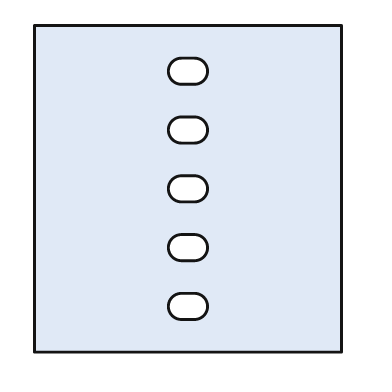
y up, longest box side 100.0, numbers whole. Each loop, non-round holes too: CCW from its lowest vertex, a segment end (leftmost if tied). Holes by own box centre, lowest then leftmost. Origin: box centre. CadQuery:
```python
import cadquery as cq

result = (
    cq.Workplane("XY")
    .moveTo(-47.0, -50.0)
    .lineTo(47.0, -50.0)
    .lineTo(47.0, 50.0)
    .lineTo(-47.0, 50.0)
    .close()
    .moveTo(-2.0, -40.0)
    .lineTo(2.0, -40.0)
    .threePointArc((6.0, -36.0), (2.0, -32.0))
    .lineTo(-2.0, -32.0)
    .threePointArc((-6.0, -36.0), (-2.0, -40.0))
    .close()
    .moveTo(-2.0, -22.0)
    .lineTo(2.0, -22.0)
    .threePointArc((6.0, -18.0), (2.0, -14.0))
    .lineTo(-2.0, -14.0)
    .threePointArc((-6.0, -18.0), (-2.0, -22.0))
    .close()
    .moveTo(-2.0, -4.0)
    .lineTo(2.0, -4.0)
    .threePointArc((6.0, 0.0), (2.0, 4.0))
    .lineTo(-2.0, 4.0)
    .threePointArc((-6.0, 0.0), (-2.0, -4.0))
    .close()
    .moveTo(-2.0, 14.0)
    .lineTo(2.0, 14.0)
    .threePointArc((6.0, 18.0), (2.0, 22.0))
    .lineTo(-2.0, 22.0)
    .threePointArc((-6.0, 18.0), (-2.0, 14.0))
    .close()
    .moveTo(-2.0, 32.0)
    .lineTo(2.0, 32.0)
    .threePointArc((6.0, 36.0), (2.0, 40.0))
    .lineTo(-2.0, 40.0)
    .threePointArc((-6.0, 36.0), (-2.0, 32.0))
    .close()
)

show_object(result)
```